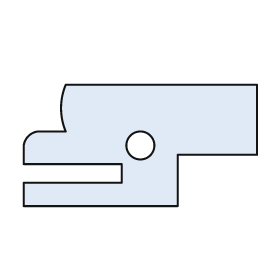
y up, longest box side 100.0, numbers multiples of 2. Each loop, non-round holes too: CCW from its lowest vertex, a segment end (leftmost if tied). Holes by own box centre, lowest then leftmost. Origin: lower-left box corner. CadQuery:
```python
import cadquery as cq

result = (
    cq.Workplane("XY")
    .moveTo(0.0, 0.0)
    .lineTo(66.0, 0.0)
    .lineTo(66.0, 22.0)
    .lineTo(100.0, 22.0)
    .lineTo(100.0, 52.0)
    .lineTo(18.0, 52.0)
    .threePointArc((16.0, 42.0), (18.0, 32.0))
    .lineTo(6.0, 32.0)
    .threePointArc((2.0, 30.0), (0.0, 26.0))
    .lineTo(0.0, 18.0)
    .lineTo(42.0, 18.0)
    .lineTo(42.0, 10.0)
    .lineTo(0.0, 10.0)
    .close()
    .moveTo(50.0, 26.0)
    .circle(6.0)
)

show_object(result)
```